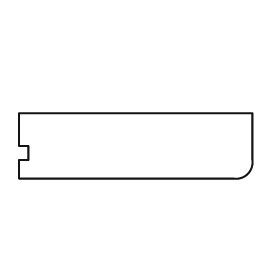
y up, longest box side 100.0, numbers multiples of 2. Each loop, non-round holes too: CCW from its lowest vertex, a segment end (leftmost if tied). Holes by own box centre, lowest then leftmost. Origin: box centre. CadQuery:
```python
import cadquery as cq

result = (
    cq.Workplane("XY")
    .moveTo(-50.0, -14.0)
    .lineTo(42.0, -14.0)
    .threePointArc((48.0, -12.0), (50.0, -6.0))
    .lineTo(50.0, 14.0)
    .lineTo(-50.0, 14.0)
    .lineTo(-50.0, 0.0)
    .lineTo(-46.0, 0.0)
    .lineTo(-46.0, -6.0)
    .lineTo(-50.0, -6.0)
    .close()
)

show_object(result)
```